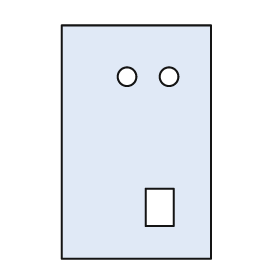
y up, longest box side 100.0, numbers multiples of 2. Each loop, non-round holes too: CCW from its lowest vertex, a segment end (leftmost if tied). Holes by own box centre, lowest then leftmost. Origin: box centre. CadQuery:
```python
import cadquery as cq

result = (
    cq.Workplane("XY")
    .moveTo(-32.0, -50.0)
    .lineTo(32.0, -50.0)
    .lineTo(32.0, 50.0)
    .lineTo(-32.0, 50.0)
    .close()
    .moveTo(4.0, -36.0)
    .lineTo(16.0, -36.0)
    .lineTo(16.0, -20.0)
    .lineTo(4.0, -20.0)
    .close()
    .moveTo(-4.0, 28.0)
    .circle(4.0)
    .moveTo(14.0, 28.0)
    .circle(4.0)
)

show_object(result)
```